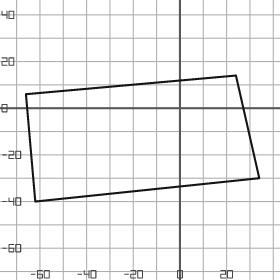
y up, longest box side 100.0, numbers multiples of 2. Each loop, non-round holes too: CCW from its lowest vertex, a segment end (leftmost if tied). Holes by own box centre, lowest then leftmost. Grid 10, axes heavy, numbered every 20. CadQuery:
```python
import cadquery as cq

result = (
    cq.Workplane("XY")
    .moveTo(-62.0, -40.0)
    .lineTo(34.0, -30.0)
    .lineTo(24.0, 14.0)
    .lineTo(-66.0, 6.0)
    .close()
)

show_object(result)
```